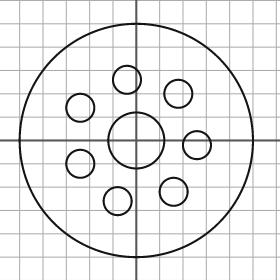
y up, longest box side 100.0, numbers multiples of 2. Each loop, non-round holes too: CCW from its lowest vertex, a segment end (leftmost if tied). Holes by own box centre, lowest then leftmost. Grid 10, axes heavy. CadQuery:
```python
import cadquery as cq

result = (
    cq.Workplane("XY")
    .moveTo(0.0, 0.0)
    .circle(50.0)
    .moveTo(-8.0, -26.0)
    .circle(6.0)
    .moveTo(16.0, -22.0)
    .circle(6.0)
    .moveTo(-24.0, -10.0)
    .circle(6.0)
    .moveTo(26.0, -2.0)
    .circle(6.0)
    .moveTo(0.0, 0.0)
    .circle(12.0)
    .moveTo(-24.0, 14.0)
    .circle(6.0)
    .moveTo(18.0, 20.0)
    .circle(6.0)
    .moveTo(-4.0, 26.0)
    .circle(6.0)
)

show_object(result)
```